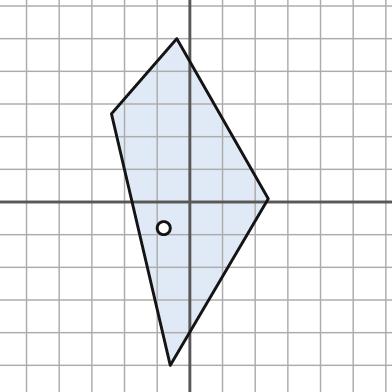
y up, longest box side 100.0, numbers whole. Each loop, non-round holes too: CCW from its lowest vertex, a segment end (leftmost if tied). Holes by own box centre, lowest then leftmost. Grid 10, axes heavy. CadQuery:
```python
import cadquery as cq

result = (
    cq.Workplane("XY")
    .moveTo(-6.0, -50.0)
    .lineTo(24.0, 1.0)
    .lineTo(-4.0, 50.0)
    .lineTo(-24.0, 27.0)
    .close()
    .moveTo(-8.0, -8.0)
    .circle(2.0)
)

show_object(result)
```